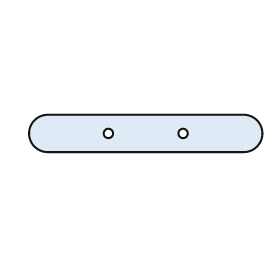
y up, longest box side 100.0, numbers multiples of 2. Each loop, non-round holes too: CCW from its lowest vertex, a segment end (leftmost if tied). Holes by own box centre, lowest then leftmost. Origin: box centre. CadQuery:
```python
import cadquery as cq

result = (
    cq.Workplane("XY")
    .moveTo(-42.0, -8.0)
    .lineTo(42.0, -8.0)
    .threePointArc((50.0, 0.0), (42.0, 8.0))
    .lineTo(-42.0, 8.0)
    .threePointArc((-50.0, 0.0), (-42.0, -8.0))
    .close()
    .moveTo(-16.0, 0.0)
    .circle(2.0)
    .moveTo(16.0, 0.0)
    .circle(2.0)
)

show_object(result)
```